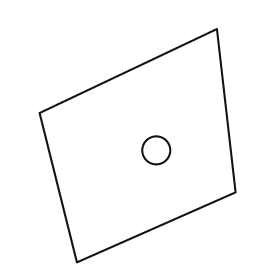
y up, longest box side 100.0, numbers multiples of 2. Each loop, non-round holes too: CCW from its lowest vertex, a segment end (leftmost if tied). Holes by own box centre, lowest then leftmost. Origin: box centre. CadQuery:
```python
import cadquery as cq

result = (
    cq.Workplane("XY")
    .moveTo(-26.0, -50.0)
    .lineTo(42.0, -20.0)
    .lineTo(34.0, 50.0)
    .lineTo(-42.0, 14.0)
    .close()
    .moveTo(8.0, -2.0)
    .circle(6.0)
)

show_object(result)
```